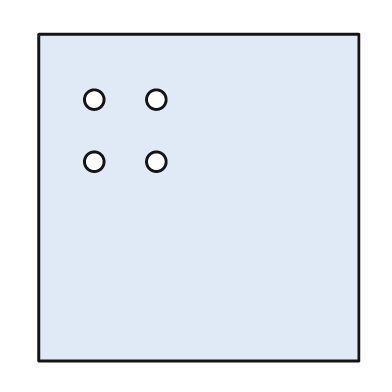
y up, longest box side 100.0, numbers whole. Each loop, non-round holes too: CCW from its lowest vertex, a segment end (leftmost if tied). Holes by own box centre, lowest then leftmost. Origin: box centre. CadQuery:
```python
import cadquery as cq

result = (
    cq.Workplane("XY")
    .moveTo(-49.0, -50.0)
    .lineTo(49.0, -50.0)
    .lineTo(49.0, 50.0)
    .lineTo(-49.0, 50.0)
    .close()
    .moveTo(-32.0, 11.0)
    .circle(3.0)
    .moveTo(-13.0, 11.0)
    .circle(3.0)
    .moveTo(-32.0, 30.0)
    .circle(3.0)
    .moveTo(-13.0, 30.0)
    .circle(3.0)
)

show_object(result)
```